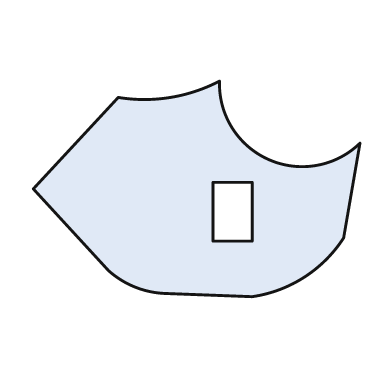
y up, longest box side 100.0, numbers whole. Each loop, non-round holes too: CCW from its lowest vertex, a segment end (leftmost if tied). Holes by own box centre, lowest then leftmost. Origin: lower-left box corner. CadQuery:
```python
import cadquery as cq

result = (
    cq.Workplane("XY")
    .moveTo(67.0, 0.0)
    .threePointArc((83.0, 6.0), (95.0, 18.0))
    .lineTo(100.0, 47.0)
    .threePointArc((72.0, 42.0), (57.0, 66.0))
    .threePointArc((42.0, 61.0), (26.0, 61.0))
    .lineTo(0.0, 33.0)
    .lineTo(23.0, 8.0)
    .threePointArc((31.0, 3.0), (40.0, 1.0))
    .close()
    .moveTo(55.0, 17.0)
    .lineTo(67.0, 17.0)
    .lineTo(67.0, 35.0)
    .lineTo(55.0, 35.0)
    .close()
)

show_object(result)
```